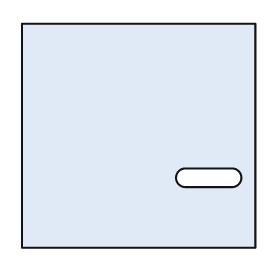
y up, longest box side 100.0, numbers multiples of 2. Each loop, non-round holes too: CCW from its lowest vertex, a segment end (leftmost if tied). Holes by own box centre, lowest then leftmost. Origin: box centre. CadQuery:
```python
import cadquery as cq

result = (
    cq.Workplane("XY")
    .moveTo(-50.0, -48.0)
    .lineTo(50.0, -48.0)
    .lineTo(50.0, 48.0)
    .lineTo(-50.0, 48.0)
    .close()
    .moveTo(20.0, -22.0)
    .lineTo(40.0, -22.0)
    .threePointArc((44.0, -18.0), (40.0, -14.0))
    .lineTo(20.0, -14.0)
    .threePointArc((16.0, -18.0), (20.0, -22.0))
    .close()
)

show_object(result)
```